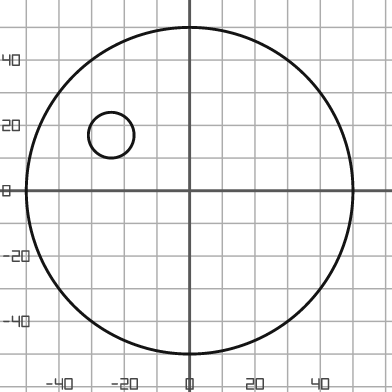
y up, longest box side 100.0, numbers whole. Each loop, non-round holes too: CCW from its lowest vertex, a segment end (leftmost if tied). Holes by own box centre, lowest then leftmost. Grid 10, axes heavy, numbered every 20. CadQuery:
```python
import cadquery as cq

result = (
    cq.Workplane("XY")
    .moveTo(0.0, 0.0)
    .circle(50.0)
    .moveTo(-24.0, 17.0)
    .circle(7.0)
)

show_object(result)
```